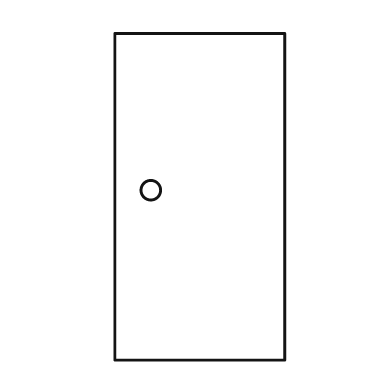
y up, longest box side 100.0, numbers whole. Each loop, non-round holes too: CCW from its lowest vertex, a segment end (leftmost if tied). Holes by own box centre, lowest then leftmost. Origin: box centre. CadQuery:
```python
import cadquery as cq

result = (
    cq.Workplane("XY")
    .moveTo(-26.0, -50.0)
    .lineTo(26.0, -50.0)
    .lineTo(26.0, 50.0)
    .lineTo(-26.0, 50.0)
    .close()
    .moveTo(-15.0, 2.0)
    .circle(3.0)
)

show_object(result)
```